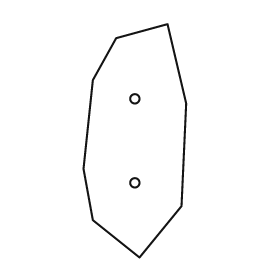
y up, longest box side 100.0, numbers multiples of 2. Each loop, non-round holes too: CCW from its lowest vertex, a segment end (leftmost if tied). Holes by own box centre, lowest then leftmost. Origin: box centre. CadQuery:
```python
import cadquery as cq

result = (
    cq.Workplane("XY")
    .moveTo(2.0, -50.0)
    .lineTo(20.0, -28.0)
    .lineTo(22.0, 16.0)
    .lineTo(14.0, 50.0)
    .lineTo(-8.0, 44.0)
    .lineTo(-18.0, 26.0)
    .lineTo(-22.0, -12.0)
    .lineTo(-18.0, -34.0)
    .close()
    .moveTo(0.0, -18.0)
    .circle(2.0)
    .moveTo(0.0, 18.0)
    .circle(2.0)
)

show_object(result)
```